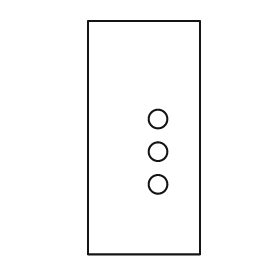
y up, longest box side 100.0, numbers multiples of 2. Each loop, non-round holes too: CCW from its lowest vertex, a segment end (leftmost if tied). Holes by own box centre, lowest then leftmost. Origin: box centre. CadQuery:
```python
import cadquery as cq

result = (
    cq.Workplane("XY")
    .moveTo(-24.0, -50.0)
    .lineTo(24.0, -50.0)
    .lineTo(24.0, 50.0)
    .lineTo(-24.0, 50.0)
    .close()
    .moveTo(6.0, -20.0)
    .circle(4.0)
    .moveTo(6.0, -6.0)
    .circle(4.0)
    .moveTo(6.0, 8.0)
    .circle(4.0)
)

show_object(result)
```